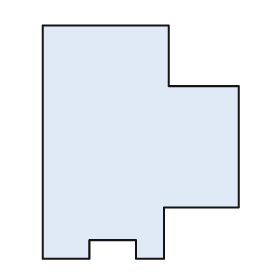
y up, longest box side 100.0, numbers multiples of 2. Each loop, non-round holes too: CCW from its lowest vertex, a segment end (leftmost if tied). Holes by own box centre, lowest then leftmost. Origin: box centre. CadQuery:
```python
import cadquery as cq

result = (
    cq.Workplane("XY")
    .moveTo(-42.0, -50.0)
    .lineTo(-22.0, -50.0)
    .lineTo(-22.0, -42.0)
    .lineTo(-2.0, -42.0)
    .lineTo(-2.0, -50.0)
    .lineTo(10.0, -50.0)
    .lineTo(10.0, -28.0)
    .lineTo(42.0, -28.0)
    .lineTo(42.0, 24.0)
    .lineTo(12.0, 24.0)
    .lineTo(12.0, 50.0)
    .lineTo(-42.0, 50.0)
    .close()
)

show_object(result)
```